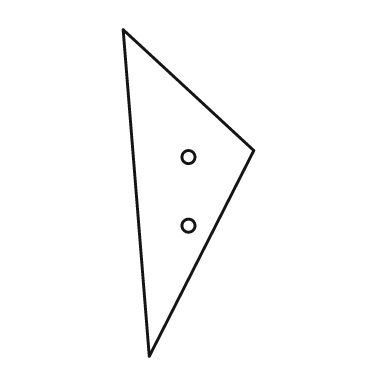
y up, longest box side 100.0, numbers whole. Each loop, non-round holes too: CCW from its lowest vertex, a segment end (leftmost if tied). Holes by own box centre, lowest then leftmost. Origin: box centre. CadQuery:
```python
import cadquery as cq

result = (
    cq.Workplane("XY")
    .moveTo(-12.0, -50.0)
    .lineTo(20.0, 13.0)
    .lineTo(-20.0, 50.0)
    .close()
    .moveTo(0.0, -10.0)
    .circle(2.0)
    .moveTo(0.0, 11.0)
    .circle(2.0)
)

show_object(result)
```